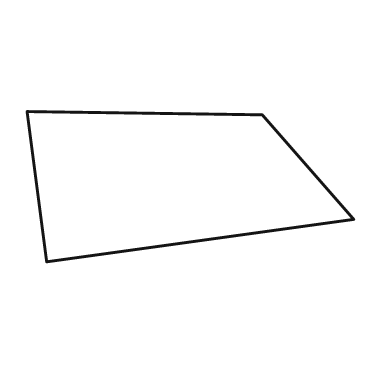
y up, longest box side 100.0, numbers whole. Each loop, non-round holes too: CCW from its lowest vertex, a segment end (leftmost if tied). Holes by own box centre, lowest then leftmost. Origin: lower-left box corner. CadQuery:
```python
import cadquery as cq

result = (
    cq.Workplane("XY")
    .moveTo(6.0, 0.0)
    .lineTo(100.0, 13.0)
    .lineTo(72.0, 45.0)
    .lineTo(0.0, 46.0)
    .close()
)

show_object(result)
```